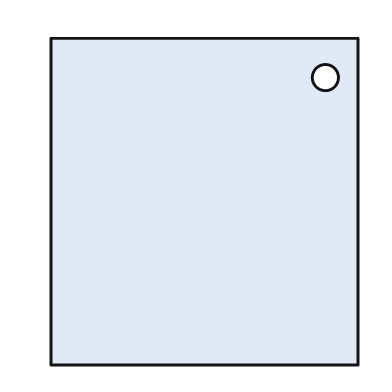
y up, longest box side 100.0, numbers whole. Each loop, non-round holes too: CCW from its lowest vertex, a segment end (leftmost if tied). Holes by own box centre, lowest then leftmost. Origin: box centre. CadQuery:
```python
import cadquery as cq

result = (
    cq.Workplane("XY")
    .moveTo(-47.0, -50.0)
    .lineTo(47.0, -50.0)
    .lineTo(47.0, 50.0)
    .lineTo(-47.0, 50.0)
    .close()
    .moveTo(37.0, 38.0)
    .circle(4.0)
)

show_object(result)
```